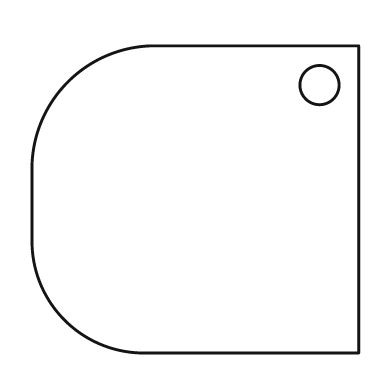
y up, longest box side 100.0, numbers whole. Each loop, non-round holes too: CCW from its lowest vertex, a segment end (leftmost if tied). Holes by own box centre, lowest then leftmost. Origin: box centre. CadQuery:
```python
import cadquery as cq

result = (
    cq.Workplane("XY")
    .moveTo(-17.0, -47.0)
    .lineTo(50.0, -47.0)
    .lineTo(50.0, 47.0)
    .lineTo(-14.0, 47.0)
    .threePointArc((-39.0, 36.0), (-50.0, 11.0))
    .lineTo(-50.0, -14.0)
    .threePointArc((-40.0, -37.0), (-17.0, -47.0))
    .close()
    .moveTo(38.0, 35.0)
    .circle(6.0)
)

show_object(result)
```